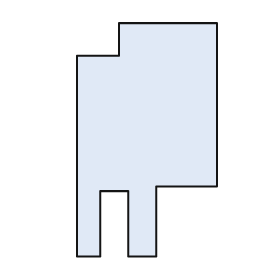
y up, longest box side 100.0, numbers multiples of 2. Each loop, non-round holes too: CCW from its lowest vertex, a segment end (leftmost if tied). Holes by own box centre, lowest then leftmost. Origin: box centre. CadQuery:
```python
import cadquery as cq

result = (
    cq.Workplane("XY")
    .moveTo(-30.0, -50.0)
    .lineTo(-20.0, -50.0)
    .lineTo(-20.0, -22.0)
    .lineTo(-8.0, -22.0)
    .lineTo(-8.0, -50.0)
    .lineTo(4.0, -50.0)
    .lineTo(4.0, -20.0)
    .lineTo(30.0, -20.0)
    .lineTo(30.0, 50.0)
    .lineTo(-12.0, 50.0)
    .lineTo(-12.0, 36.0)
    .lineTo(-30.0, 36.0)
    .close()
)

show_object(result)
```